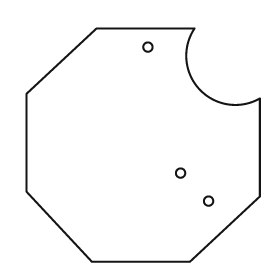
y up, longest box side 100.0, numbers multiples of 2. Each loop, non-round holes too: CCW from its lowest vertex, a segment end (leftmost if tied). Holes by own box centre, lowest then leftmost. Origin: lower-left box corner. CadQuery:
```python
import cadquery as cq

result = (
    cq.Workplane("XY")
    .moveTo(28.0, 0.0)
    .lineTo(70.0, 0.0)
    .lineTo(100.0, 28.0)
    .lineTo(100.0, 70.0)
    .threePointArc((74.0, 74.0), (72.0, 100.0))
    .lineTo(30.0, 100.0)
    .lineTo(0.0, 72.0)
    .lineTo(0.0, 30.0)
    .close()
    .moveTo(78.0, 26.0)
    .circle(2.0)
    .moveTo(66.0, 38.0)
    .circle(2.0)
    .moveTo(52.0, 92.0)
    .circle(2.0)
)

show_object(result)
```